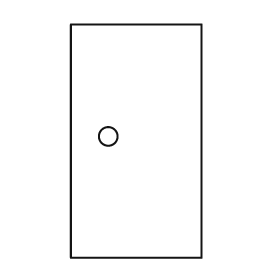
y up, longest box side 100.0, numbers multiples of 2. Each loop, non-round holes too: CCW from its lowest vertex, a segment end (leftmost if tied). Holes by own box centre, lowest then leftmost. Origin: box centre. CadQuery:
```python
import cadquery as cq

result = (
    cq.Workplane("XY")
    .moveTo(-28.0, -50.0)
    .lineTo(28.0, -50.0)
    .lineTo(28.0, 50.0)
    .lineTo(-28.0, 50.0)
    .close()
    .moveTo(-12.0, 2.0)
    .circle(4.0)
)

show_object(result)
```